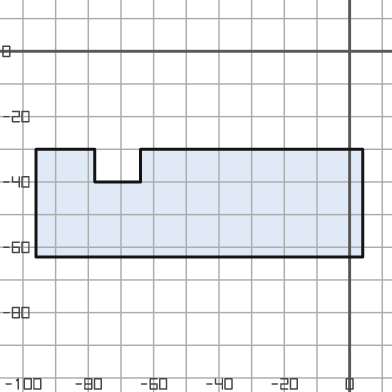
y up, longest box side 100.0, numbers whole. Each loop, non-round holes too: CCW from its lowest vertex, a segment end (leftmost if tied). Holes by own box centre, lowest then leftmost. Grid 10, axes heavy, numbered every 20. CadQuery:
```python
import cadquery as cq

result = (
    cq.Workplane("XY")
    .moveTo(-96.0, -63.0)
    .lineTo(4.0, -63.0)
    .lineTo(4.0, -30.0)
    .lineTo(-64.0, -30.0)
    .lineTo(-64.0, -40.0)
    .lineTo(-78.0, -40.0)
    .lineTo(-78.0, -30.0)
    .lineTo(-96.0, -30.0)
    .close()
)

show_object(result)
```